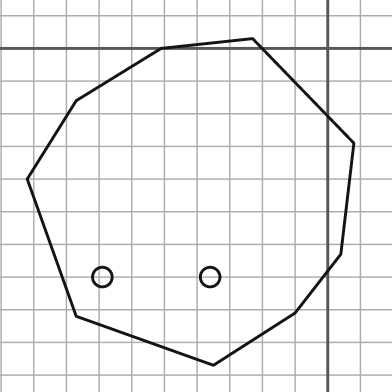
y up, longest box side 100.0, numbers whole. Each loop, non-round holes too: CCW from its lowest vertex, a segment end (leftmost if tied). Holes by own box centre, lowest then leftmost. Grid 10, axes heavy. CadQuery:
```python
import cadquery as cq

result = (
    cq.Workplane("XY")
    .moveTo(-35.0, -97.0)
    .lineTo(-10.0, -81.0)
    .lineTo(4.0, -63.0)
    .lineTo(8.0, -29.0)
    .lineTo(-23.0, 3.0)
    .lineTo(-51.0, 0.0)
    .lineTo(-77.0, -16.0)
    .lineTo(-92.0, -40.0)
    .lineTo(-77.0, -82.0)
    .close()
    .moveTo(-69.0, -70.0)
    .circle(3.0)
    .moveTo(-36.0, -70.0)
    .circle(3.0)
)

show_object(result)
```